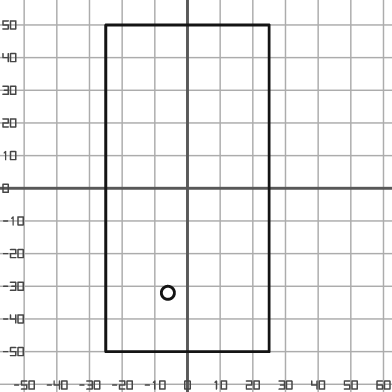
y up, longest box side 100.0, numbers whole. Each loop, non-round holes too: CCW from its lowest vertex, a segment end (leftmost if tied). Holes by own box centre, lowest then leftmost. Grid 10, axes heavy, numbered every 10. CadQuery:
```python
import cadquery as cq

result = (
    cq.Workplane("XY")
    .moveTo(-25.0, -50.0)
    .lineTo(25.0, -50.0)
    .lineTo(25.0, 50.0)
    .lineTo(-25.0, 50.0)
    .close()
    .moveTo(-6.0, -32.0)
    .circle(2.0)
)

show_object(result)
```